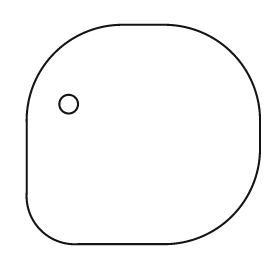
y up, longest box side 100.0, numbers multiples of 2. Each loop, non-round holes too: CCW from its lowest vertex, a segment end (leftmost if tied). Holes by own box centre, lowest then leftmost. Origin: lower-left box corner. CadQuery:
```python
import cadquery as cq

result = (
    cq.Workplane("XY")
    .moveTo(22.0, 0.0)
    .lineTo(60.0, 0.0)
    .threePointArc((88.0, 12.0), (100.0, 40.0))
    .lineTo(100.0, 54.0)
    .threePointArc((88.0, 82.0), (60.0, 94.0))
    .lineTo(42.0, 94.0)
    .threePointArc((12.0, 82.0), (0.0, 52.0))
    .lineTo(0.0, 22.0)
    .threePointArc((6.0, 6.0), (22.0, 0.0))
    .close()
    .moveTo(18.0, 60.0)
    .circle(4.0)
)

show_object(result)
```